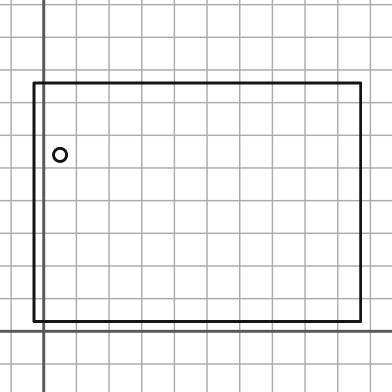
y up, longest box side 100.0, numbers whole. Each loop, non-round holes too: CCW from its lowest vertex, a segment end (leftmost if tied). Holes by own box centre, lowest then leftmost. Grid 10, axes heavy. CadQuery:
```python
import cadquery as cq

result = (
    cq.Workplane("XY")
    .moveTo(-3.0, 3.0)
    .lineTo(97.0, 3.0)
    .lineTo(97.0, 76.0)
    .lineTo(-3.0, 76.0)
    .close()
    .moveTo(5.0, 54.0)
    .circle(2.0)
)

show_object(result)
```